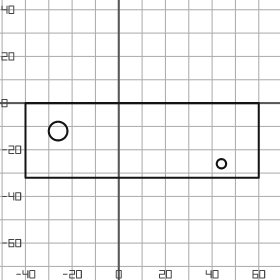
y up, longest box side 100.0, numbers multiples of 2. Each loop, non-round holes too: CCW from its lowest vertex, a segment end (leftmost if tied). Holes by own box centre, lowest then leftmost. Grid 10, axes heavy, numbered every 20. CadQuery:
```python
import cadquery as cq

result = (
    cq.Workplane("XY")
    .moveTo(-40.0, -32.0)
    .lineTo(60.0, -32.0)
    .lineTo(60.0, 0.0)
    .lineTo(-40.0, 0.0)
    .close()
    .moveTo(44.0, -26.0)
    .circle(2.0)
    .moveTo(-26.0, -12.0)
    .circle(4.0)
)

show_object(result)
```